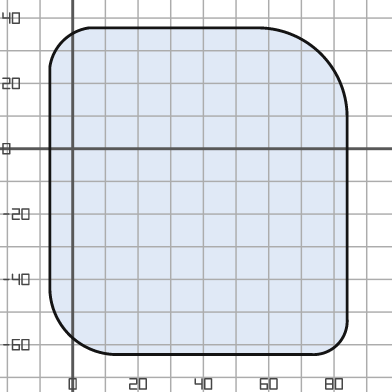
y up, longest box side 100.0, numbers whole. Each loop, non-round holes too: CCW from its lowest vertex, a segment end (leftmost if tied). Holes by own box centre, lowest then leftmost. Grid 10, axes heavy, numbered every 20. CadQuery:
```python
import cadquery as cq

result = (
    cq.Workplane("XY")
    .moveTo(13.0, -63.0)
    .lineTo(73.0, -63.0)
    .threePointArc((81.0, -60.0), (84.0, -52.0))
    .lineTo(84.0, 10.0)
    .threePointArc((76.0, 29.0), (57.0, 37.0))
    .lineTo(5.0, 37.0)
    .threePointArc((-3.0, 33.0), (-7.0, 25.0))
    .lineTo(-7.0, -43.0)
    .threePointArc((-1.0, -57.0), (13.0, -63.0))
    .close()
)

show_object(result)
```